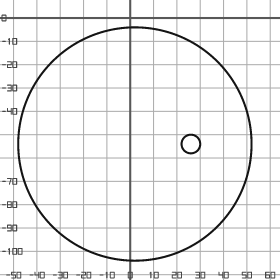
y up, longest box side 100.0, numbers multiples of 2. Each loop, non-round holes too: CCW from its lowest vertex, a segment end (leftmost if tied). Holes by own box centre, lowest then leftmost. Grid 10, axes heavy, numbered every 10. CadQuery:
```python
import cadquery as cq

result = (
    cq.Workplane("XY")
    .moveTo(2.0, -54.0)
    .circle(50.0)
    .moveTo(26.0, -54.0)
    .circle(4.0)
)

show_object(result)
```